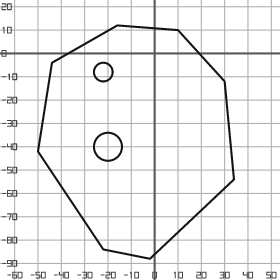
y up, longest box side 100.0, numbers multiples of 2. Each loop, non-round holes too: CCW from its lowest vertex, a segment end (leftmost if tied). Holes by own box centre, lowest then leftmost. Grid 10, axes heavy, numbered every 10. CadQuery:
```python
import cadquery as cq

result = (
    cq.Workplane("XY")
    .moveTo(-2.0, -88.0)
    .lineTo(34.0, -54.0)
    .lineTo(30.0, -12.0)
    .lineTo(10.0, 10.0)
    .lineTo(-16.0, 12.0)
    .lineTo(-44.0, -4.0)
    .lineTo(-50.0, -42.0)
    .lineTo(-22.0, -84.0)
    .close()
    .moveTo(-20.0, -40.0)
    .circle(6.0)
    .moveTo(-22.0, -8.0)
    .circle(4.0)
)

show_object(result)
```